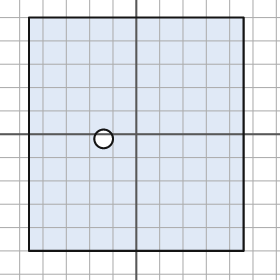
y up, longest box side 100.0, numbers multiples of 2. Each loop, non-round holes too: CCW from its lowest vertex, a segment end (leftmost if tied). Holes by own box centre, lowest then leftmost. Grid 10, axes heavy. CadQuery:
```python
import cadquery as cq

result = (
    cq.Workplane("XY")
    .moveTo(-46.0, -50.0)
    .lineTo(46.0, -50.0)
    .lineTo(46.0, 50.0)
    .lineTo(-46.0, 50.0)
    .close()
    .moveTo(-14.0, -2.0)
    .circle(4.0)
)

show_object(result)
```